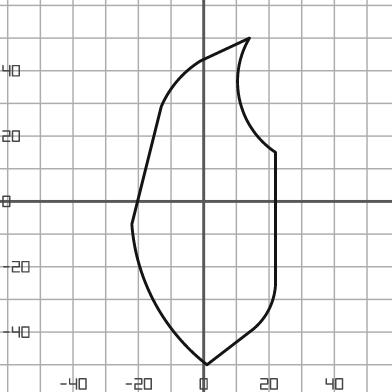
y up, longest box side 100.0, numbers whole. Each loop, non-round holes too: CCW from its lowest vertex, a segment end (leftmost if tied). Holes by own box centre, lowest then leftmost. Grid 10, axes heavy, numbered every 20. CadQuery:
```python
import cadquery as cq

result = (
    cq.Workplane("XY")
    .moveTo(1.0, -50.0)
    .lineTo(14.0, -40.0)
    .threePointArc((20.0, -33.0), (22.0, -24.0))
    .lineTo(22.0, 15.0)
    .threePointArc((11.0, 31.0), (14.0, 50.0))
    .lineTo(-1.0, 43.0)
    .threePointArc((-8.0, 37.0), (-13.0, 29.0))
    .lineTo(-22.0, -7.0)
    .threePointArc((-15.0, -31.0), (1.0, -50.0))
    .close()
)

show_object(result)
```